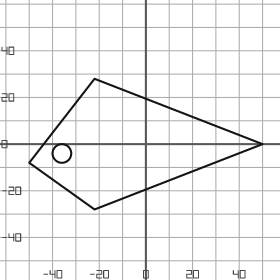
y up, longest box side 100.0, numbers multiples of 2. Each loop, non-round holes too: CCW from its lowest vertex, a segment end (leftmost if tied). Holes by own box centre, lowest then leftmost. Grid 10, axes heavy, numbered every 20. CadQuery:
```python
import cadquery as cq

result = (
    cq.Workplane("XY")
    .moveTo(-22.0, -28.0)
    .lineTo(50.0, 0.0)
    .lineTo(-22.0, 28.0)
    .lineTo(-50.0, -8.0)
    .close()
    .moveTo(-36.0, -4.0)
    .circle(4.0)
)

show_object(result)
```